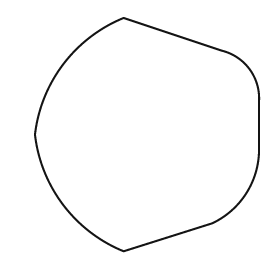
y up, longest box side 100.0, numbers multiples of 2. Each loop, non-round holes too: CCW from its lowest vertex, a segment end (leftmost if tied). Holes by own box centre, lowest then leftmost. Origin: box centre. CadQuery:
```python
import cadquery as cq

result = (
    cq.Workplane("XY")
    .moveTo(-10.0, -50.0)
    .lineTo(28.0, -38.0)
    .threePointArc((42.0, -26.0), (48.0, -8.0))
    .lineTo(48.0, 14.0)
    .threePointArc((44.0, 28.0), (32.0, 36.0))
    .lineTo(-10.0, 50.0)
    .threePointArc((-36.0, 30.0), (-48.0, 0.0))
    .threePointArc((-36.0, -30.0), (-10.0, -50.0))
    .close()
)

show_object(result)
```